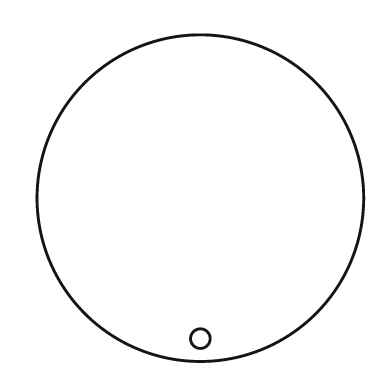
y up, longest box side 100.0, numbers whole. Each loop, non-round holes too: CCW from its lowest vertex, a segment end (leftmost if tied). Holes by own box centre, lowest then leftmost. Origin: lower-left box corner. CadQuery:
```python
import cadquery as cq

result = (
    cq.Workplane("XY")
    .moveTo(50.0, 50.0)
    .circle(50.0)
    .moveTo(50.0, 7.0)
    .circle(3.0)
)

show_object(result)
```